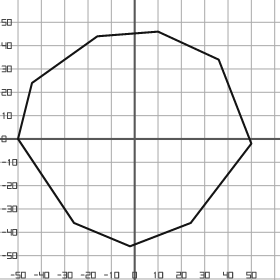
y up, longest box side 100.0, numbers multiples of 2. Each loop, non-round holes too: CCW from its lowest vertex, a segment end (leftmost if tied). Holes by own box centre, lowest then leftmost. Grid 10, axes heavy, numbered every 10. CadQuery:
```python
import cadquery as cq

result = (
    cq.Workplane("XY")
    .moveTo(-2.0, -46.0)
    .lineTo(24.0, -36.0)
    .lineTo(50.0, -2.0)
    .lineTo(36.0, 34.0)
    .lineTo(10.0, 46.0)
    .lineTo(-16.0, 44.0)
    .lineTo(-44.0, 24.0)
    .lineTo(-50.0, 0.0)
    .lineTo(-26.0, -36.0)
    .close()
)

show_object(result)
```